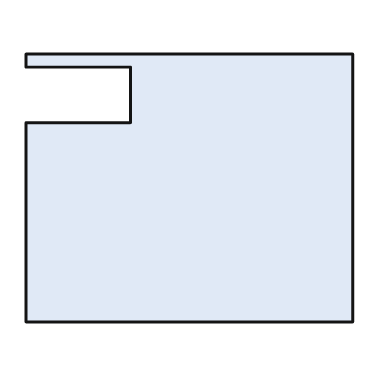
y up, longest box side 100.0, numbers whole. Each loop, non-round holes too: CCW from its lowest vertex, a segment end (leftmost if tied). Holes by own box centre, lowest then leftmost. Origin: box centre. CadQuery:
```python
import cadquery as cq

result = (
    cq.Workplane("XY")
    .moveTo(-50.0, -41.0)
    .lineTo(50.0, -41.0)
    .lineTo(50.0, 41.0)
    .lineTo(-50.0, 41.0)
    .lineTo(-50.0, 37.0)
    .lineTo(-18.0, 37.0)
    .lineTo(-18.0, 20.0)
    .lineTo(-50.0, 20.0)
    .close()
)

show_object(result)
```